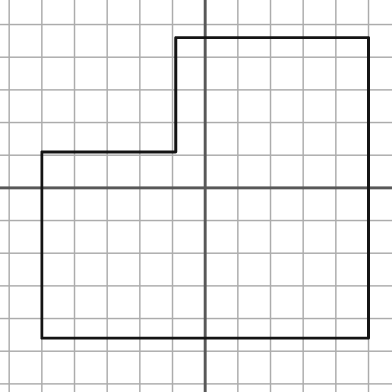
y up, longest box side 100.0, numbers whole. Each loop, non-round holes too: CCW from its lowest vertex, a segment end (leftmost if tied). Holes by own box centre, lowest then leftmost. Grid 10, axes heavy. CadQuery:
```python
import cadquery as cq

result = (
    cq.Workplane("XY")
    .moveTo(-50.0, -46.0)
    .lineTo(50.0, -46.0)
    .lineTo(50.0, 46.0)
    .lineTo(-9.0, 46.0)
    .lineTo(-9.0, 11.0)
    .lineTo(-50.0, 11.0)
    .close()
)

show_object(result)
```